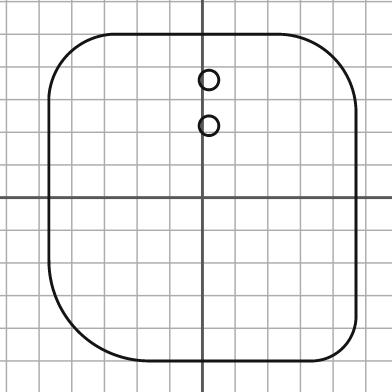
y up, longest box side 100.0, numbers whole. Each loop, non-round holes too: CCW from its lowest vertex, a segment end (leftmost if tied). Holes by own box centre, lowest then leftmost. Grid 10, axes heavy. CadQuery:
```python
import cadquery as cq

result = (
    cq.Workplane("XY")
    .moveTo(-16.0, -50.0)
    .lineTo(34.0, -50.0)
    .threePointArc((43.0, -46.0), (47.0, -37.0))
    .lineTo(47.0, 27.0)
    .threePointArc((40.0, 43.0), (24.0, 50.0))
    .lineTo(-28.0, 50.0)
    .threePointArc((-41.0, 44.0), (-47.0, 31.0))
    .lineTo(-47.0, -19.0)
    .threePointArc((-38.0, -41.0), (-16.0, -50.0))
    .close()
    .moveTo(2.0, 22.0)
    .circle(3.0)
    .moveTo(2.0, 36.0)
    .circle(3.0)
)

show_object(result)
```